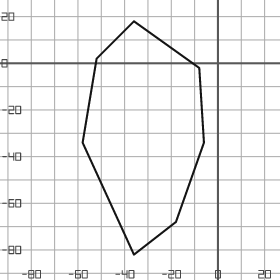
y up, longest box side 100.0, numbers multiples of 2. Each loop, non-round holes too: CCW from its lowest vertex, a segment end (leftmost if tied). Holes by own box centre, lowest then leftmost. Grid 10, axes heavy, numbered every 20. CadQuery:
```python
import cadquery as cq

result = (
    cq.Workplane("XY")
    .moveTo(-36.0, -82.0)
    .lineTo(-18.0, -68.0)
    .lineTo(-6.0, -34.0)
    .lineTo(-8.0, -2.0)
    .lineTo(-36.0, 18.0)
    .lineTo(-52.0, 2.0)
    .lineTo(-58.0, -34.0)
    .close()
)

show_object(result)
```